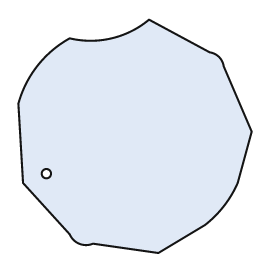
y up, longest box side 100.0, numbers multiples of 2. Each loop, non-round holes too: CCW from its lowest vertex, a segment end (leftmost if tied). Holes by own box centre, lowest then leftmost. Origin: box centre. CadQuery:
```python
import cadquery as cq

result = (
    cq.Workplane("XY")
    .moveTo(10.0, -50.0)
    .lineTo(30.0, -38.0)
    .threePointArc((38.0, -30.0), (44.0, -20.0))
    .lineTo(50.0, 2.0)
    .lineTo(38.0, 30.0)
    .threePointArc((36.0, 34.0), (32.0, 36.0))
    .lineTo(6.0, 50.0)
    .threePointArc((-10.0, 42.0), (-28.0, 42.0))
    .threePointArc((-42.0, 30.0), (-50.0, 14.0))
    .lineTo(-48.0, -20.0)
    .lineTo(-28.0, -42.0)
    .threePointArc((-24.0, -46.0), (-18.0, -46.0))
    .close()
    .moveTo(-38.0, -16.0)
    .circle(2.0)
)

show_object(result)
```